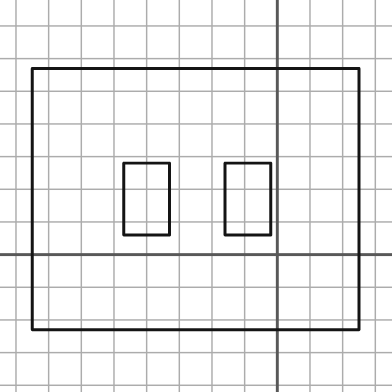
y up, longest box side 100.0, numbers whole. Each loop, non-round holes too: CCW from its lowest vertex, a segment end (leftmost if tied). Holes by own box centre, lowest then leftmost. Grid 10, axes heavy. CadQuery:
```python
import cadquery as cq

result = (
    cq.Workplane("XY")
    .moveTo(-75.0, -23.0)
    .lineTo(25.0, -23.0)
    .lineTo(25.0, 57.0)
    .lineTo(-75.0, 57.0)
    .close()
    .moveTo(-47.0, 6.0)
    .lineTo(-33.0, 6.0)
    .lineTo(-33.0, 28.0)
    .lineTo(-47.0, 28.0)
    .close()
    .moveTo(-16.0, 6.0)
    .lineTo(-2.0, 6.0)
    .lineTo(-2.0, 28.0)
    .lineTo(-16.0, 28.0)
    .close()
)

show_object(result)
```